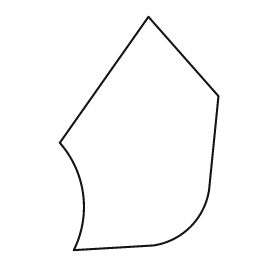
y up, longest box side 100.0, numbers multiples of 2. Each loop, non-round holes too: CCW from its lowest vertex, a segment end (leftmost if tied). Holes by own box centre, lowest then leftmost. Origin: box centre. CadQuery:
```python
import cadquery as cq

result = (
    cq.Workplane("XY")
    .moveTo(-28.0, -50.0)
    .lineTo(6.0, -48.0)
    .threePointArc((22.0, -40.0), (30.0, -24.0))
    .lineTo(34.0, 16.0)
    .lineTo(4.0, 50.0)
    .lineTo(-34.0, -4.0)
    .threePointArc((-24.0, -26.0), (-28.0, -50.0))
    .close()
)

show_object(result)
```